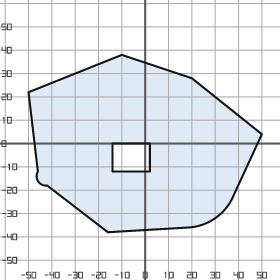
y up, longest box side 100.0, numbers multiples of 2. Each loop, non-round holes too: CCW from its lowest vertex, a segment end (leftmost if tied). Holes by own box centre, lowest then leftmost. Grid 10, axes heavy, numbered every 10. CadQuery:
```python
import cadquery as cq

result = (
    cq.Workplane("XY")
    .moveTo(-16.0, -38.0)
    .lineTo(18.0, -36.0)
    .threePointArc((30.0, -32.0), (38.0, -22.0))
    .lineTo(50.0, 4.0)
    .lineTo(20.0, 28.0)
    .lineTo(-10.0, 38.0)
    .lineTo(-50.0, 22.0)
    .lineTo(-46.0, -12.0)
    .threePointArc((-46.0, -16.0), (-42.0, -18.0))
    .close()
    .moveTo(-14.0, -12.0)
    .lineTo(2.0, -12.0)
    .lineTo(2.0, 0.0)
    .lineTo(-14.0, 0.0)
    .close()
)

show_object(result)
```